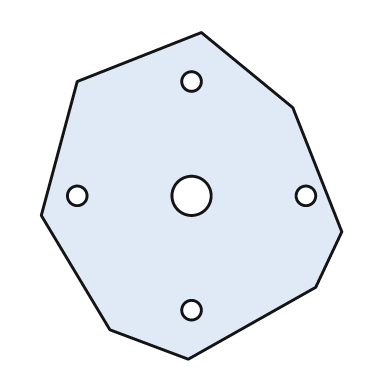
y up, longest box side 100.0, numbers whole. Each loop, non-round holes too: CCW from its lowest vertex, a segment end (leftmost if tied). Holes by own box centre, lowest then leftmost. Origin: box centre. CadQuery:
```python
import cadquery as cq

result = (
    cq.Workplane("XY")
    .moveTo(-1.0, -50.0)
    .lineTo(38.0, -28.0)
    .lineTo(46.0, -11.0)
    .lineTo(31.0, 27.0)
    .lineTo(3.0, 50.0)
    .lineTo(-35.0, 35.0)
    .lineTo(-46.0, -6.0)
    .lineTo(-25.0, -41.0)
    .close()
    .moveTo(0.0, -35.0)
    .circle(3.0)
    .moveTo(-35.0, 0.0)
    .circle(3.0)
    .moveTo(0.0, 0.0)
    .circle(6.0)
    .moveTo(35.0, 0.0)
    .circle(3.0)
    .moveTo(0.0, 35.0)
    .circle(3.0)
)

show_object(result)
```